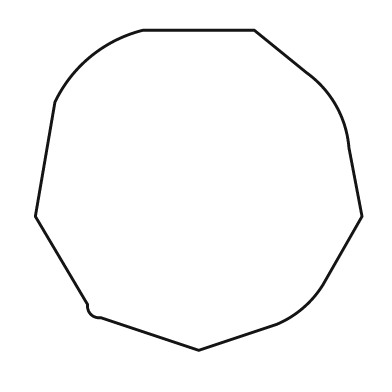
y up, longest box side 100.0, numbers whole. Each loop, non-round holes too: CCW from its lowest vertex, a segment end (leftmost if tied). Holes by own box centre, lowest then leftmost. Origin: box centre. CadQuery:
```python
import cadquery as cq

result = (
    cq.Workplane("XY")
    .moveTo(0.0, -49.0)
    .lineTo(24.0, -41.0)
    .threePointArc((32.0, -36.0), (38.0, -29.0))
    .lineTo(50.0, -8.0)
    .lineTo(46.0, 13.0)
    .threePointArc((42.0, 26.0), (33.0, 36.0))
    .lineTo(17.0, 49.0)
    .lineTo(-17.0, 49.0)
    .threePointArc((-33.0, 41.0), (-44.0, 27.0))
    .lineTo(-50.0, -8.0)
    .lineTo(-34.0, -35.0)
    .threePointArc((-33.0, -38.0), (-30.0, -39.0))
    .close()
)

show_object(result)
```